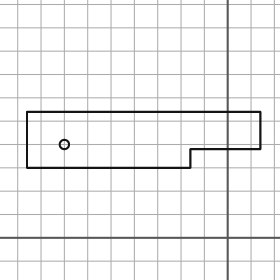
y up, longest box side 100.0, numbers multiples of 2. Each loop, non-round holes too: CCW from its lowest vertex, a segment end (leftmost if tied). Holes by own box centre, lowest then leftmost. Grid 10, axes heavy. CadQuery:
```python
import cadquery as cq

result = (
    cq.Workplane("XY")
    .moveTo(-86.0, 30.0)
    .lineTo(-16.0, 30.0)
    .lineTo(-16.0, 38.0)
    .lineTo(14.0, 38.0)
    .lineTo(14.0, 54.0)
    .lineTo(-86.0, 54.0)
    .close()
    .moveTo(-70.0, 40.0)
    .circle(2.0)
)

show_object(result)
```